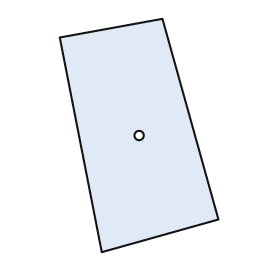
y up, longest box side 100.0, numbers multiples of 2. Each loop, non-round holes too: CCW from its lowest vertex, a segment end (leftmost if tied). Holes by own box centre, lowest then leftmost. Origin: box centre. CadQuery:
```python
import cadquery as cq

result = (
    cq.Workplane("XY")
    .moveTo(-16.0, -50.0)
    .lineTo(34.0, -36.0)
    .lineTo(10.0, 50.0)
    .lineTo(-34.0, 42.0)
    .close()
    .moveTo(0.0, 0.0)
    .circle(2.0)
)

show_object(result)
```